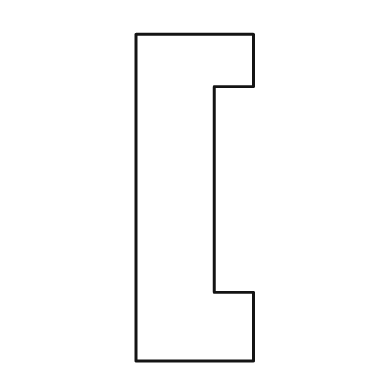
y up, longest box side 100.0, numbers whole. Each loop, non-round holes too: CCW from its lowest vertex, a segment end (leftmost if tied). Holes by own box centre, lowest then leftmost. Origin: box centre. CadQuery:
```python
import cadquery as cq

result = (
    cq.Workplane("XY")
    .moveTo(-18.0, -50.0)
    .lineTo(18.0, -50.0)
    .lineTo(18.0, -29.0)
    .lineTo(6.0, -29.0)
    .lineTo(6.0, 34.0)
    .lineTo(18.0, 34.0)
    .lineTo(18.0, 50.0)
    .lineTo(-18.0, 50.0)
    .close()
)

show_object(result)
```